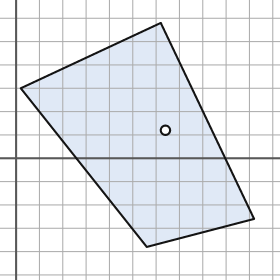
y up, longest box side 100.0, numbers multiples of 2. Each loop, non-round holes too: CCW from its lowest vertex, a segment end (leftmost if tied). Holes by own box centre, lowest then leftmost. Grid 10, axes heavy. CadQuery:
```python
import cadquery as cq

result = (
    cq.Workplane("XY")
    .moveTo(56.0, -38.0)
    .lineTo(102.0, -26.0)
    .lineTo(62.0, 58.0)
    .lineTo(2.0, 30.0)
    .close()
    .moveTo(64.0, 12.0)
    .circle(2.0)
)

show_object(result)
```